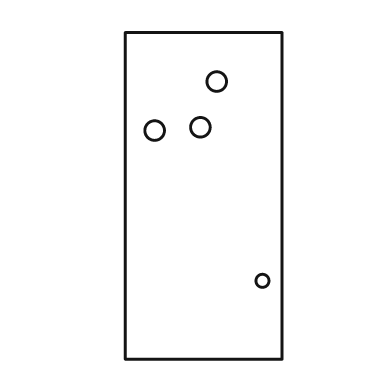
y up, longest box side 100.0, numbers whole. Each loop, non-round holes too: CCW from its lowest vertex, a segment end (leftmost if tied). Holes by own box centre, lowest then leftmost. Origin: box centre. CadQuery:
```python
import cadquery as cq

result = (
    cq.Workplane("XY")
    .moveTo(-24.0, -50.0)
    .lineTo(24.0, -50.0)
    .lineTo(24.0, 50.0)
    .lineTo(-24.0, 50.0)
    .close()
    .moveTo(18.0, -26.0)
    .circle(2.0)
    .moveTo(-15.0, 20.0)
    .circle(3.0)
    .moveTo(-1.0, 21.0)
    .circle(3.0)
    .moveTo(4.0, 35.0)
    .circle(3.0)
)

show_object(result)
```